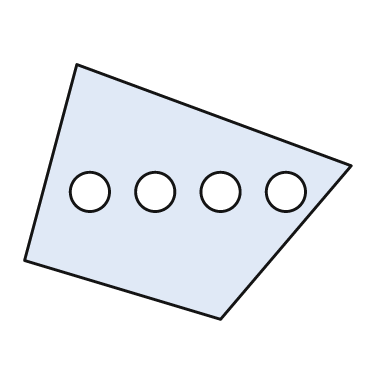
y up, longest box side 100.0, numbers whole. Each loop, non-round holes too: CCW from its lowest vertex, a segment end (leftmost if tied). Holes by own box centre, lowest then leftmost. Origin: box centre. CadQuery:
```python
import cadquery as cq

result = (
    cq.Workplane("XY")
    .moveTo(10.0, -39.0)
    .lineTo(50.0, 8.0)
    .lineTo(-34.0, 39.0)
    .lineTo(-50.0, -21.0)
    .close()
    .moveTo(-30.0, 0.0)
    .circle(6.0)
    .moveTo(-10.0, 0.0)
    .circle(6.0)
    .moveTo(10.0, 0.0)
    .circle(6.0)
    .moveTo(30.0, 0.0)
    .circle(6.0)
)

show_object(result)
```